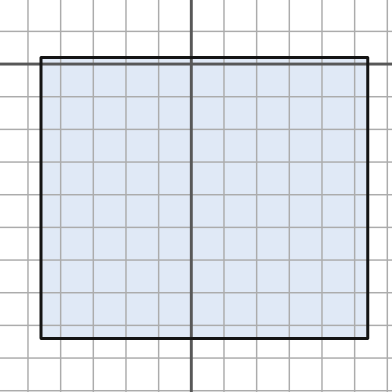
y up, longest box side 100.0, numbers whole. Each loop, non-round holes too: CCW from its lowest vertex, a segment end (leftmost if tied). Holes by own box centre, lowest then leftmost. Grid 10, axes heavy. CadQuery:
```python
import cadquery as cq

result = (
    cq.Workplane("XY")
    .moveTo(-46.0, -84.0)
    .lineTo(54.0, -84.0)
    .lineTo(54.0, 2.0)
    .lineTo(-46.0, 2.0)
    .close()
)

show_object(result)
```